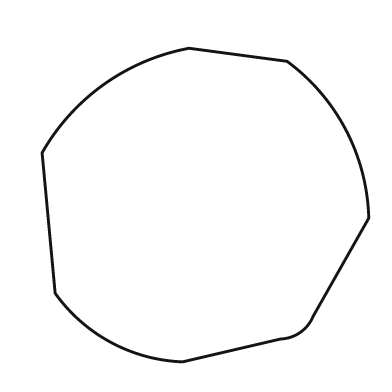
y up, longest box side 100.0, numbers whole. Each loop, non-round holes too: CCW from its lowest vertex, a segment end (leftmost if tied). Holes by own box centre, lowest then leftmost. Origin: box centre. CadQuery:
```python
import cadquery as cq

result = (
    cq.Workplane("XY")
    .moveTo(-7.0, -48.0)
    .lineTo(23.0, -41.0)
    .threePointArc((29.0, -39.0), (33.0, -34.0))
    .lineTo(50.0, -4.0)
    .threePointArc((43.0, 23.0), (25.0, 44.0))
    .lineTo(-5.0, 48.0)
    .threePointArc((-31.0, 37.0), (-50.0, 16.0))
    .lineTo(-46.0, -27.0)
    .threePointArc((-29.0, -42.0), (-7.0, -48.0))
    .close()
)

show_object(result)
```